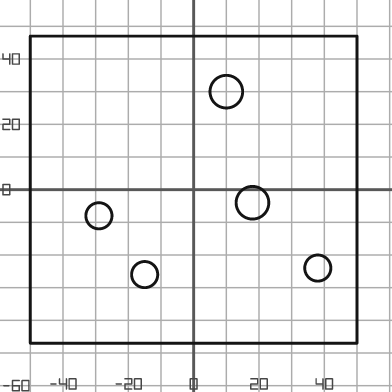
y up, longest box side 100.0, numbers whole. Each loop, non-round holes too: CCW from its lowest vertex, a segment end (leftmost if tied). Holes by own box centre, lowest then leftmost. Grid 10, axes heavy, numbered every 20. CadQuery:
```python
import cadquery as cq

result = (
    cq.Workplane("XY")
    .moveTo(-50.0, -47.0)
    .lineTo(50.0, -47.0)
    .lineTo(50.0, 47.0)
    .lineTo(-50.0, 47.0)
    .close()
    .moveTo(-15.0, -26.0)
    .circle(4.0)
    .moveTo(38.0, -24.0)
    .circle(4.0)
    .moveTo(-29.0, -8.0)
    .circle(4.0)
    .moveTo(18.0, -4.0)
    .circle(5.0)
    .moveTo(10.0, 30.0)
    .circle(5.0)
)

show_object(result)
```